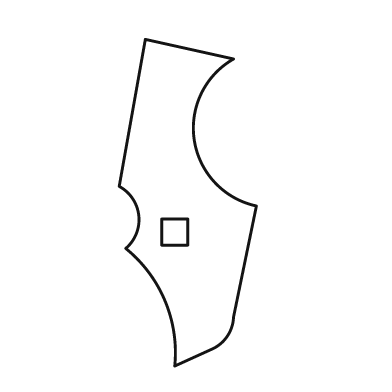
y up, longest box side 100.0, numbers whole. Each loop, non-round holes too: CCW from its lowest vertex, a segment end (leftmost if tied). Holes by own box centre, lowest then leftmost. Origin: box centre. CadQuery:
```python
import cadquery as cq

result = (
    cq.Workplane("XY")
    .moveTo(-4.0, -50.0)
    .lineTo(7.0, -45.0)
    .threePointArc((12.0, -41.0), (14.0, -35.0))
    .lineTo(21.0, -1.0)
    .threePointArc((2.0, 19.0), (14.0, 44.0))
    .lineTo(-13.0, 50.0)
    .lineTo(-21.0, 5.0)
    .threePointArc((-15.0, -4.0), (-19.0, -14.0))
    .threePointArc((-7.0, -30.0), (-4.0, -50.0))
    .close()
    .moveTo(-8.0, -13.0)
    .lineTo(0.0, -13.0)
    .lineTo(0.0, -5.0)
    .lineTo(-8.0, -5.0)
    .close()
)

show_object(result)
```